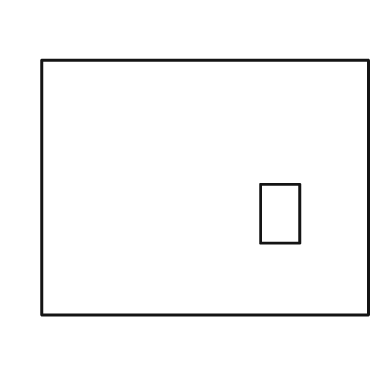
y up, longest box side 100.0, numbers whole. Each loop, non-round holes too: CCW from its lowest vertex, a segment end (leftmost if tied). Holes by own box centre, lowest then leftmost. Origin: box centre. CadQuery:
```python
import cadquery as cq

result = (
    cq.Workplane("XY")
    .moveTo(-50.0, -39.0)
    .lineTo(50.0, -39.0)
    .lineTo(50.0, 39.0)
    .lineTo(-50.0, 39.0)
    .close()
    .moveTo(17.0, -17.0)
    .lineTo(29.0, -17.0)
    .lineTo(29.0, 1.0)
    .lineTo(17.0, 1.0)
    .close()
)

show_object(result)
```